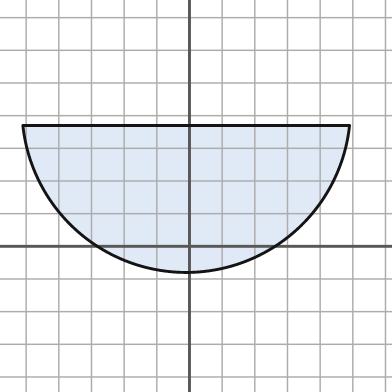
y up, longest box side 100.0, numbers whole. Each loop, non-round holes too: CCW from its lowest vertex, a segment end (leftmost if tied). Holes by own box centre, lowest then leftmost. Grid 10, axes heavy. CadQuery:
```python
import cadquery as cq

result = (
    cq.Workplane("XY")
    .moveTo(-51.0, 37.0)
    .threePointArc((-1.0, -8.0), (49.0, 37.0))
    .close()
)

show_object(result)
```